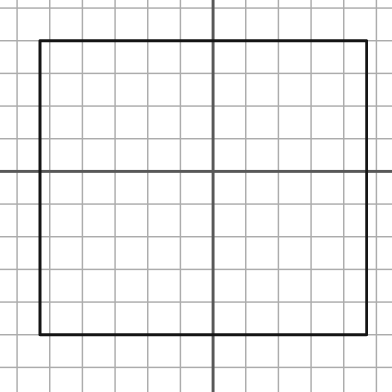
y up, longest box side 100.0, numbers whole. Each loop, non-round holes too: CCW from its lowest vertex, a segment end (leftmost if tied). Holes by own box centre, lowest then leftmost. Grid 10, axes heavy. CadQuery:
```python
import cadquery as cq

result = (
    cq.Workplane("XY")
    .moveTo(-53.0, -50.0)
    .lineTo(47.0, -50.0)
    .lineTo(47.0, 40.0)
    .lineTo(-53.0, 40.0)
    .close()
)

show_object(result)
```